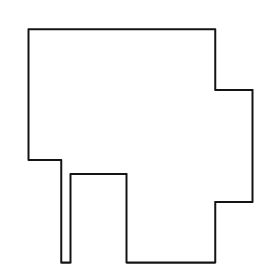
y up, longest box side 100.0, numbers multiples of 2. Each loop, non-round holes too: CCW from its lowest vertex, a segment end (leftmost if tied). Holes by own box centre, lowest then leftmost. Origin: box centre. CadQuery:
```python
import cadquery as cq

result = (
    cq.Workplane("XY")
    .moveTo(-34.0, -50.0)
    .lineTo(-30.0, -50.0)
    .lineTo(-30.0, -12.0)
    .lineTo(-6.0, -12.0)
    .lineTo(-6.0, -50.0)
    .lineTo(32.0, -50.0)
    .lineTo(32.0, -24.0)
    .lineTo(48.0, -24.0)
    .lineTo(48.0, 24.0)
    .lineTo(32.0, 24.0)
    .lineTo(32.0, 50.0)
    .lineTo(-48.0, 50.0)
    .lineTo(-48.0, -6.0)
    .lineTo(-34.0, -6.0)
    .close()
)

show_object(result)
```